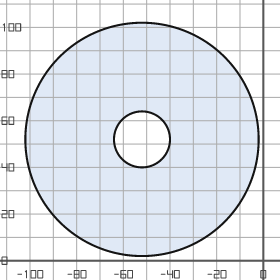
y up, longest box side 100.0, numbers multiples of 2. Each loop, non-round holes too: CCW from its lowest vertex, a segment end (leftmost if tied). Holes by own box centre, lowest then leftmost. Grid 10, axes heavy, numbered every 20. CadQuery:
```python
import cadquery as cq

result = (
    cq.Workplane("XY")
    .moveTo(-52.0, 52.0)
    .circle(50.0)
    .moveTo(-52.0, 52.0)
    .circle(12.0)
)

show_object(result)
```